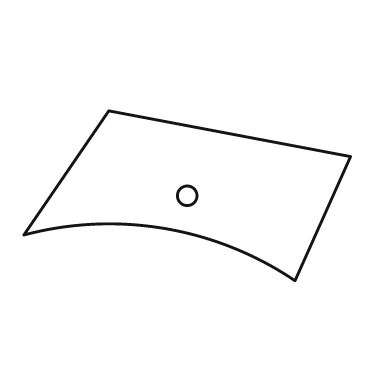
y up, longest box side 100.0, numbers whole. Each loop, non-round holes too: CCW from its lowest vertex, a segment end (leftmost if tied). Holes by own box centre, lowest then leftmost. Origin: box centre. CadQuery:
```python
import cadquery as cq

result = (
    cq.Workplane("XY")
    .moveTo(33.0, -26.0)
    .lineTo(50.0, 12.0)
    .lineTo(-24.0, 26.0)
    .lineTo(-50.0, -12.0)
    .threePointArc((-7.0, -10.0), (33.0, -26.0))
    .close()
    .moveTo(0.0, 0.0)
    .circle(3.0)
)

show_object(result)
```